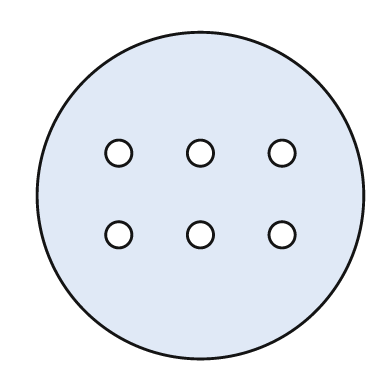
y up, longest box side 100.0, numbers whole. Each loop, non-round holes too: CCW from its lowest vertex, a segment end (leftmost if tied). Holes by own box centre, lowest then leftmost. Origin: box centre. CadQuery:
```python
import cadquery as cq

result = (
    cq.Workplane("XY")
    .moveTo(0.0, 0.0)
    .circle(50.0)
    .moveTo(-25.0, -12.0)
    .circle(4.0)
    .moveTo(0.0, -12.0)
    .circle(4.0)
    .moveTo(25.0, -12.0)
    .circle(4.0)
    .moveTo(-25.0, 13.0)
    .circle(4.0)
    .moveTo(0.0, 13.0)
    .circle(4.0)
    .moveTo(25.0, 13.0)
    .circle(4.0)
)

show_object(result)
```